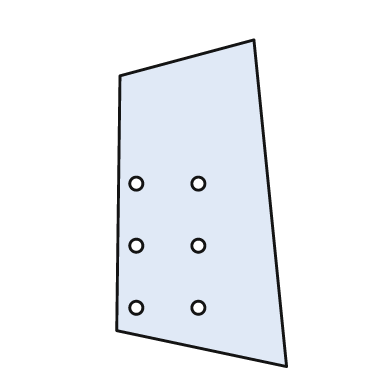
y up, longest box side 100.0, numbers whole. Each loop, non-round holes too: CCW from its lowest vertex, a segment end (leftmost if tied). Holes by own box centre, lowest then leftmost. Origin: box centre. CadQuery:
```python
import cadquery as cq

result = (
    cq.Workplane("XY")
    .moveTo(26.0, -50.0)
    .lineTo(16.0, 50.0)
    .lineTo(-25.0, 39.0)
    .lineTo(-26.0, -39.0)
    .close()
    .moveTo(-20.0, -32.0)
    .circle(2.0)
    .moveTo(-1.0, -32.0)
    .circle(2.0)
    .moveTo(-20.0, -13.0)
    .circle(2.0)
    .moveTo(-1.0, -13.0)
    .circle(2.0)
    .moveTo(-20.0, 6.0)
    .circle(2.0)
    .moveTo(-1.0, 6.0)
    .circle(2.0)
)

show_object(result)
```